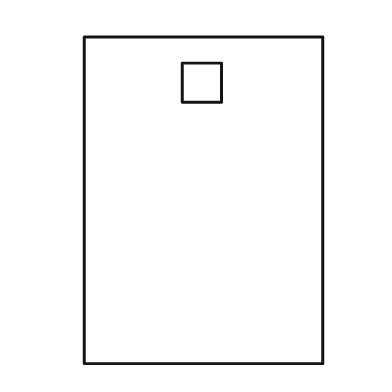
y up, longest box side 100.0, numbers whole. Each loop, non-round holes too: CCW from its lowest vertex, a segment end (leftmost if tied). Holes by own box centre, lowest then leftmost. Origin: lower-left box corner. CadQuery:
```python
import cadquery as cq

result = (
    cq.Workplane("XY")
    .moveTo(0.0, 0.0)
    .lineTo(73.0, 0.0)
    .lineTo(73.0, 100.0)
    .lineTo(0.0, 100.0)
    .close()
    .moveTo(30.0, 80.0)
    .lineTo(42.0, 80.0)
    .lineTo(42.0, 92.0)
    .lineTo(30.0, 92.0)
    .close()
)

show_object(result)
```